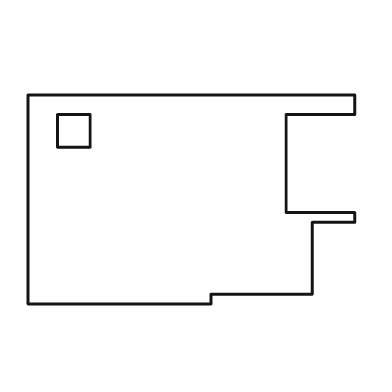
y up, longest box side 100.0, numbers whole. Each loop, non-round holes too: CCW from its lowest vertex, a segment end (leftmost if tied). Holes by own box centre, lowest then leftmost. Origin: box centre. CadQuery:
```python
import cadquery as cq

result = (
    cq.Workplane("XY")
    .moveTo(-50.0, -32.0)
    .lineTo(6.0, -32.0)
    .lineTo(6.0, -29.0)
    .lineTo(37.0, -29.0)
    .lineTo(37.0, -7.0)
    .lineTo(50.0, -7.0)
    .lineTo(50.0, -4.0)
    .lineTo(29.0, -4.0)
    .lineTo(29.0, 26.0)
    .lineTo(50.0, 26.0)
    .lineTo(50.0, 32.0)
    .lineTo(-50.0, 32.0)
    .close()
    .moveTo(-41.0, 16.0)
    .lineTo(-31.0, 16.0)
    .lineTo(-31.0, 26.0)
    .lineTo(-41.0, 26.0)
    .close()
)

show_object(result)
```